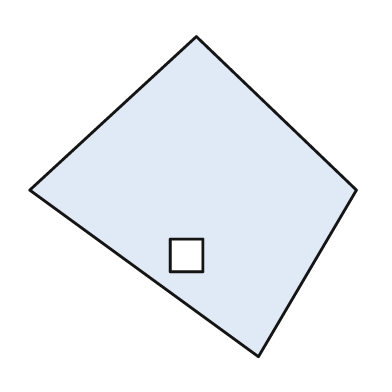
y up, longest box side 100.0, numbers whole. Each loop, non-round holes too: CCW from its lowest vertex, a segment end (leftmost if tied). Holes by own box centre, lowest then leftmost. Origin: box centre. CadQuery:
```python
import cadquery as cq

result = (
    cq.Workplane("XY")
    .moveTo(20.0, -49.0)
    .lineTo(50.0, 2.0)
    .lineTo(1.0, 49.0)
    .lineTo(-50.0, 2.0)
    .close()
    .moveTo(-7.0, -23.0)
    .lineTo(3.0, -23.0)
    .lineTo(3.0, -13.0)
    .lineTo(-7.0, -13.0)
    .close()
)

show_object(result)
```